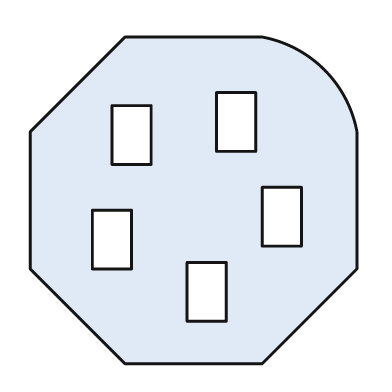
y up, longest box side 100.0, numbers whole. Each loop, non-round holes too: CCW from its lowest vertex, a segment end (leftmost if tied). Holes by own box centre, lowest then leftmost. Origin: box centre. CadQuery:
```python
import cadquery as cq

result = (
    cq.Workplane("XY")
    .moveTo(-21.0, -50.0)
    .lineTo(21.0, -50.0)
    .lineTo(50.0, -21.0)
    .lineTo(50.0, 21.0)
    .threePointArc((40.0, 40.0), (21.0, 50.0))
    .lineTo(-21.0, 50.0)
    .lineTo(-50.0, 21.0)
    .lineTo(-50.0, -21.0)
    .close()
    .moveTo(-2.0, -37.0)
    .lineTo(10.0, -37.0)
    .lineTo(10.0, -19.0)
    .lineTo(-2.0, -19.0)
    .close()
    .moveTo(-31.0, -21.0)
    .lineTo(-19.0, -21.0)
    .lineTo(-19.0, -3.0)
    .lineTo(-31.0, -3.0)
    .close()
    .moveTo(21.0, -14.0)
    .lineTo(33.0, -14.0)
    .lineTo(33.0, 4.0)
    .lineTo(21.0, 4.0)
    .close()
    .moveTo(-25.0, 11.0)
    .lineTo(-13.0, 11.0)
    .lineTo(-13.0, 29.0)
    .lineTo(-25.0, 29.0)
    .close()
    .moveTo(7.0, 15.0)
    .lineTo(19.0, 15.0)
    .lineTo(19.0, 33.0)
    .lineTo(7.0, 33.0)
    .close()
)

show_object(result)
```